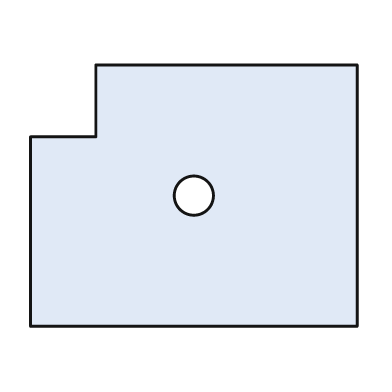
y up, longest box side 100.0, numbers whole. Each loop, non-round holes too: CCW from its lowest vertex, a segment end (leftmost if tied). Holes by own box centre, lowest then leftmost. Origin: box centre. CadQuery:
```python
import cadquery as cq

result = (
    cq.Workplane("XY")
    .moveTo(-50.0, -40.0)
    .lineTo(50.0, -40.0)
    .lineTo(50.0, 40.0)
    .lineTo(-30.0, 40.0)
    .lineTo(-30.0, 18.0)
    .lineTo(-50.0, 18.0)
    .close()
    .moveTo(0.0, 0.0)
    .circle(6.0)
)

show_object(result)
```